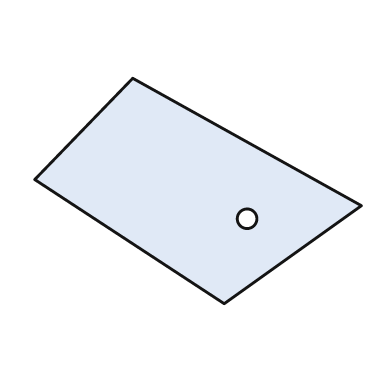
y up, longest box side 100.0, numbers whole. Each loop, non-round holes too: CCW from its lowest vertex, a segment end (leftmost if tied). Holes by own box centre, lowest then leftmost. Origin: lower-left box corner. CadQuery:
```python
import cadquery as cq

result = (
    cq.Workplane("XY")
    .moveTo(58.0, 0.0)
    .lineTo(100.0, 30.0)
    .lineTo(30.0, 69.0)
    .lineTo(0.0, 38.0)
    .close()
    .moveTo(65.0, 26.0)
    .circle(3.0)
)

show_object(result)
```